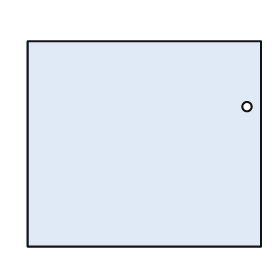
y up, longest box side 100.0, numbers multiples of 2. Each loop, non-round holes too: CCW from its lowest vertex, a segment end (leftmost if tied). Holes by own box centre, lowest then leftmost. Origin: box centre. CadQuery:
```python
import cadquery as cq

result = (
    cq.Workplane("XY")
    .moveTo(-50.0, -44.0)
    .lineTo(50.0, -44.0)
    .lineTo(50.0, 44.0)
    .lineTo(-50.0, 44.0)
    .close()
    .moveTo(44.0, 16.0)
    .circle(2.0)
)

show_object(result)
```